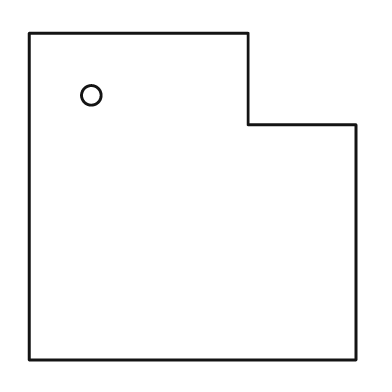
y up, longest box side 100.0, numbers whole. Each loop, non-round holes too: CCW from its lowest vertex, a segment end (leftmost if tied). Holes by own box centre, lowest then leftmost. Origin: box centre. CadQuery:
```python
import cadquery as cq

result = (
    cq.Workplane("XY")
    .moveTo(-50.0, -50.0)
    .lineTo(50.0, -50.0)
    .lineTo(50.0, 22.0)
    .lineTo(17.0, 22.0)
    .lineTo(17.0, 50.0)
    .lineTo(-50.0, 50.0)
    .close()
    .moveTo(-31.0, 31.0)
    .circle(3.0)
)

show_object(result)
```